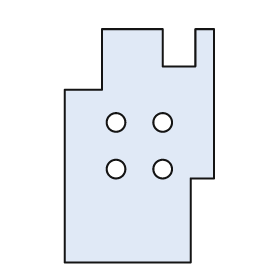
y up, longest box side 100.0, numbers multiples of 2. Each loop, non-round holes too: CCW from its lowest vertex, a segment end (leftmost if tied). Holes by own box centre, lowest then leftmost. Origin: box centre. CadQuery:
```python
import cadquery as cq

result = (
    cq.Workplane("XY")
    .moveTo(-32.0, -50.0)
    .lineTo(22.0, -50.0)
    .lineTo(22.0, -14.0)
    .lineTo(32.0, -14.0)
    .lineTo(32.0, 50.0)
    .lineTo(24.0, 50.0)
    .lineTo(24.0, 34.0)
    .lineTo(10.0, 34.0)
    .lineTo(10.0, 50.0)
    .lineTo(-16.0, 50.0)
    .lineTo(-16.0, 24.0)
    .lineTo(-32.0, 24.0)
    .close()
    .moveTo(-10.0, -10.0)
    .circle(4.0)
    .moveTo(10.0, -10.0)
    .circle(4.0)
    .moveTo(-10.0, 10.0)
    .circle(4.0)
    .moveTo(10.0, 10.0)
    .circle(4.0)
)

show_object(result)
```